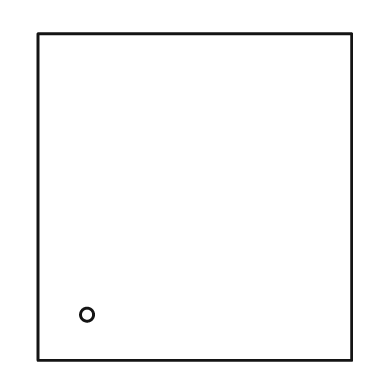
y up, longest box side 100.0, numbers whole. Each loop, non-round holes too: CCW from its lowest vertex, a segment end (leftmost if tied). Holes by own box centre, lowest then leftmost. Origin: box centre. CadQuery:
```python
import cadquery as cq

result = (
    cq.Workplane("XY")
    .moveTo(-48.0, -50.0)
    .lineTo(48.0, -50.0)
    .lineTo(48.0, 50.0)
    .lineTo(-48.0, 50.0)
    .close()
    .moveTo(-33.0, -36.0)
    .circle(2.0)
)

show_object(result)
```